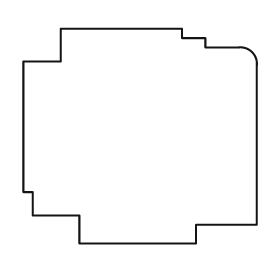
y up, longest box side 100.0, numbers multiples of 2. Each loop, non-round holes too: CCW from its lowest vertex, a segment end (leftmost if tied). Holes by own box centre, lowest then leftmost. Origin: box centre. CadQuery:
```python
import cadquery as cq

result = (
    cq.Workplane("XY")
    .moveTo(-26.0, -46.0)
    .lineTo(24.0, -46.0)
    .lineTo(24.0, -38.0)
    .lineTo(50.0, -38.0)
    .lineTo(50.0, 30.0)
    .threePointArc((48.0, 36.0), (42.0, 38.0))
    .lineTo(28.0, 38.0)
    .lineTo(28.0, 42.0)
    .lineTo(18.0, 42.0)
    .lineTo(18.0, 46.0)
    .lineTo(-34.0, 46.0)
    .lineTo(-34.0, 32.0)
    .lineTo(-50.0, 32.0)
    .lineTo(-50.0, -24.0)
    .lineTo(-46.0, -24.0)
    .lineTo(-46.0, -34.0)
    .lineTo(-26.0, -34.0)
    .close()
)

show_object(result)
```